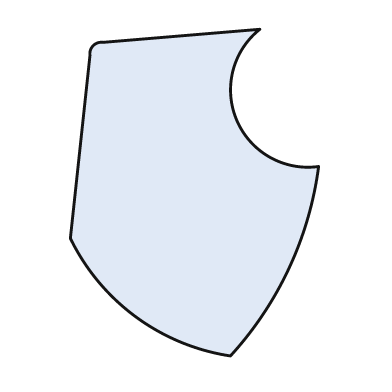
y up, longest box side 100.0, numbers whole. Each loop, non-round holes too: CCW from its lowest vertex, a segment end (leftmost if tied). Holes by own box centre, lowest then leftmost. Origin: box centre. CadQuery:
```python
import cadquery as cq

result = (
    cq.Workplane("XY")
    .moveTo(11.0, -50.0)
    .threePointArc((29.0, -23.0), (38.0, 8.0))
    .threePointArc((13.0, 22.0), (20.0, 50.0))
    .lineTo(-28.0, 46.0)
    .threePointArc((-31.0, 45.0), (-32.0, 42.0))
    .lineTo(-38.0, -14.0)
    .threePointArc((-18.0, -38.0), (11.0, -50.0))
    .close()
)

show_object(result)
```